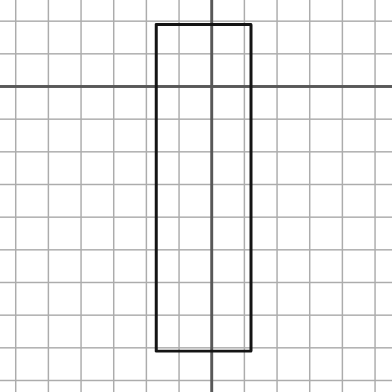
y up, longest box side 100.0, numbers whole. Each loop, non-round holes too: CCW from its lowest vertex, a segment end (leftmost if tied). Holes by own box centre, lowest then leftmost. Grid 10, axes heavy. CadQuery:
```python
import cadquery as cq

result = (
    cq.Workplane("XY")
    .moveTo(-17.0, -81.0)
    .lineTo(12.0, -81.0)
    .lineTo(12.0, 19.0)
    .lineTo(-17.0, 19.0)
    .close()
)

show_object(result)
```